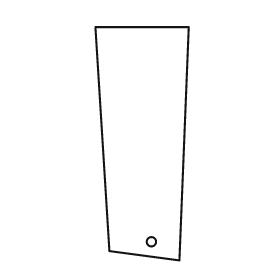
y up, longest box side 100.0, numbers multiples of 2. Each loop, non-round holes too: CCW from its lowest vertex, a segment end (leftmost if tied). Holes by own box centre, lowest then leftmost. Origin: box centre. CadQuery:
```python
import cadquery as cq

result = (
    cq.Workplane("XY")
    .moveTo(16.0, -50.0)
    .lineTo(20.0, 50.0)
    .lineTo(-20.0, 50.0)
    .lineTo(-14.0, -46.0)
    .close()
    .moveTo(4.0, -42.0)
    .circle(2.0)
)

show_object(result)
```